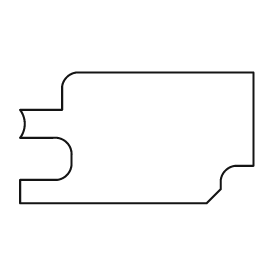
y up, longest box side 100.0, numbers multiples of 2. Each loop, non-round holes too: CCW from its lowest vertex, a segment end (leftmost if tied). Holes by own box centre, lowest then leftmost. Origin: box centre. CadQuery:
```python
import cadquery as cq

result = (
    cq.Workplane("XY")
    .moveTo(-50.0, -28.0)
    .lineTo(30.0, -28.0)
    .lineTo(36.0, -22.0)
    .lineTo(36.0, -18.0)
    .threePointArc((38.0, -14.0), (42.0, -12.0))
    .lineTo(50.0, -12.0)
    .lineTo(50.0, 28.0)
    .lineTo(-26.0, 28.0)
    .threePointArc((-30.0, 26.0), (-32.0, 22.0))
    .lineTo(-32.0, 12.0)
    .lineTo(-50.0, 12.0)
    .threePointArc((-48.0, 6.0), (-50.0, 0.0))
    .lineTo(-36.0, 0.0)
    .threePointArc((-30.0, -2.0), (-28.0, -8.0))
    .lineTo(-28.0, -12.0)
    .threePointArc((-30.0, -16.0), (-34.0, -18.0))
    .lineTo(-50.0, -18.0)
    .close()
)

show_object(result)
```